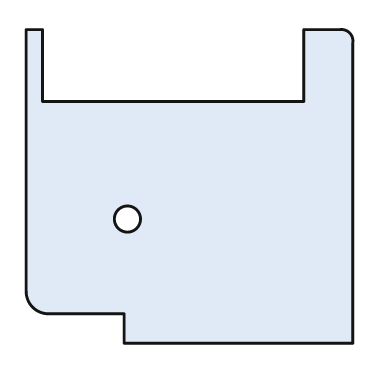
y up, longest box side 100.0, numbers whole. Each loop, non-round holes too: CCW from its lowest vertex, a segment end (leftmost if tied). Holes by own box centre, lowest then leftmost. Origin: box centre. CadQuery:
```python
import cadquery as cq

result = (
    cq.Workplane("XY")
    .moveTo(-20.0, -48.0)
    .lineTo(50.0, -48.0)
    .lineTo(50.0, 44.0)
    .threePointArc((49.0, 47.0), (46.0, 48.0))
    .lineTo(35.0, 48.0)
    .lineTo(35.0, 26.0)
    .lineTo(-45.0, 26.0)
    .lineTo(-45.0, 48.0)
    .lineTo(-50.0, 48.0)
    .lineTo(-50.0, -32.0)
    .threePointArc((-48.0, -37.0), (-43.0, -39.0))
    .lineTo(-20.0, -39.0)
    .close()
    .moveTo(-19.0, -10.0)
    .circle(4.0)
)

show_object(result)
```